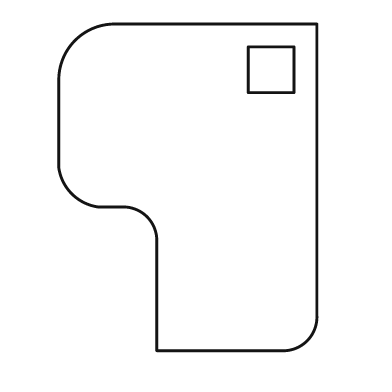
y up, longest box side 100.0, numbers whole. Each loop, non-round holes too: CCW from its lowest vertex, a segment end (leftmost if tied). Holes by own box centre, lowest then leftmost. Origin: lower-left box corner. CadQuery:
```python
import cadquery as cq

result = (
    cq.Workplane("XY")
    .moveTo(30.0, 0.0)
    .lineTo(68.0, 0.0)
    .threePointArc((76.0, 3.0), (79.0, 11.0))
    .lineTo(79.0, 100.0)
    .lineTo(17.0, 100.0)
    .threePointArc((5.0, 95.0), (0.0, 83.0))
    .lineTo(0.0, 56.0)
    .threePointArc((4.0, 48.0), (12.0, 44.0))
    .lineTo(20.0, 44.0)
    .threePointArc((27.0, 41.0), (30.0, 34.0))
    .close()
    .moveTo(58.0, 79.0)
    .lineTo(72.0, 79.0)
    .lineTo(72.0, 93.0)
    .lineTo(58.0, 93.0)
    .close()
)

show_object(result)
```